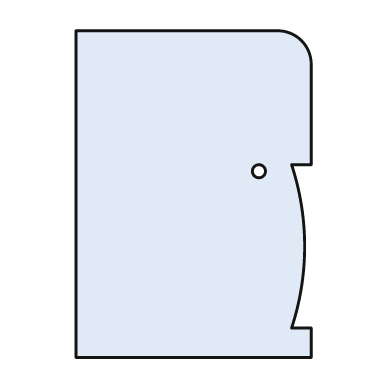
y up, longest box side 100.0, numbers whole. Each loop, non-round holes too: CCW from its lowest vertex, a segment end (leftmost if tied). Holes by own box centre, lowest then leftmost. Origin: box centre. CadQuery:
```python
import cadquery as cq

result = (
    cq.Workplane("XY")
    .moveTo(-36.0, -50.0)
    .lineTo(36.0, -50.0)
    .lineTo(36.0, -41.0)
    .lineTo(30.0, -41.0)
    .threePointArc((34.0, -16.0), (30.0, 9.0))
    .lineTo(36.0, 9.0)
    .lineTo(36.0, 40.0)
    .threePointArc((33.0, 47.0), (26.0, 50.0))
    .lineTo(-36.0, 50.0)
    .close()
    .moveTo(20.0, 7.0)
    .circle(2.0)
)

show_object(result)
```